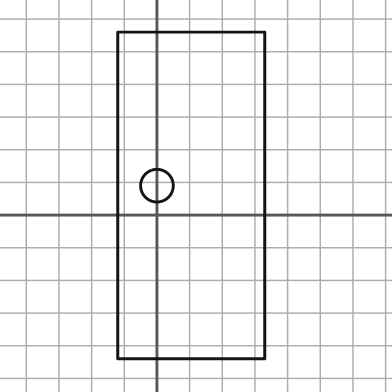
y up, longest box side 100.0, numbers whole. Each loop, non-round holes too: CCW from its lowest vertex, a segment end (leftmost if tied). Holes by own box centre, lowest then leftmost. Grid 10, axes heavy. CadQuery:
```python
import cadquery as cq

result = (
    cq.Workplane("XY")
    .moveTo(-12.0, -44.0)
    .lineTo(33.0, -44.0)
    .lineTo(33.0, 56.0)
    .lineTo(-12.0, 56.0)
    .close()
    .moveTo(0.0, 9.0)
    .circle(5.0)
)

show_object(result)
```